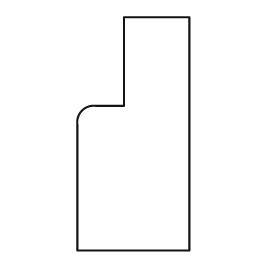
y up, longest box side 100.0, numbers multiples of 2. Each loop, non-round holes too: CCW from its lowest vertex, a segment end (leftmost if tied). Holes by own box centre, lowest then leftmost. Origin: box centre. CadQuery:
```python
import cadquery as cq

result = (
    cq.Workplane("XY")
    .moveTo(-24.0, -50.0)
    .lineTo(24.0, -50.0)
    .lineTo(24.0, 50.0)
    .lineTo(-4.0, 50.0)
    .lineTo(-4.0, 12.0)
    .lineTo(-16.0, 12.0)
    .threePointArc((-22.0, 10.0), (-24.0, 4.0))
    .close()
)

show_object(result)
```